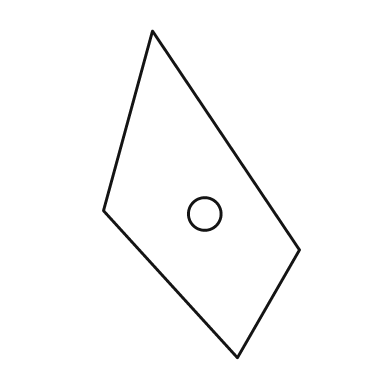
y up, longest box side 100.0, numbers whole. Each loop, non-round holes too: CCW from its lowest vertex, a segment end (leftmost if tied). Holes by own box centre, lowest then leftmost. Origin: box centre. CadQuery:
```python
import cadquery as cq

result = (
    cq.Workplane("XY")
    .moveTo(11.0, -50.0)
    .lineTo(30.0, -17.0)
    .lineTo(-15.0, 50.0)
    .lineTo(-30.0, -5.0)
    .close()
    .moveTo(1.0, -6.0)
    .circle(5.0)
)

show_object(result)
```